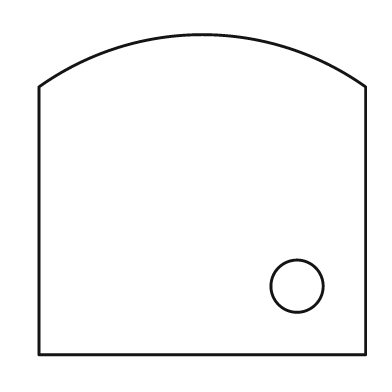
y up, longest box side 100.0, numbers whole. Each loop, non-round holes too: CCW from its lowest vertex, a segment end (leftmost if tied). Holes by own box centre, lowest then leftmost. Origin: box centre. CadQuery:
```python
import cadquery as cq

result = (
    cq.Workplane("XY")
    .moveTo(-50.0, -49.0)
    .lineTo(50.0, -49.0)
    .lineTo(50.0, 33.0)
    .threePointArc((0.0, 49.0), (-50.0, 33.0))
    .close()
    .moveTo(29.0, -28.0)
    .circle(8.0)
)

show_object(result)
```